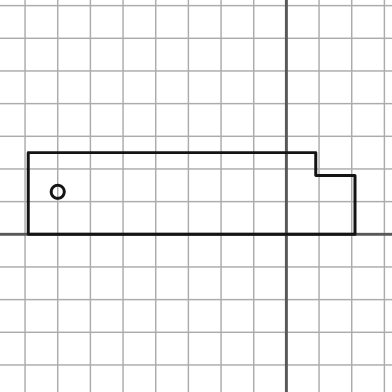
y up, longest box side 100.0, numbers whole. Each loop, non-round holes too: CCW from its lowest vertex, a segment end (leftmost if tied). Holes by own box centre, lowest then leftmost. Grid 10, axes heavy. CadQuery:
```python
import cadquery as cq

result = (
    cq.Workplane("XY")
    .moveTo(-79.0, 0.0)
    .lineTo(21.0, 0.0)
    .lineTo(21.0, 18.0)
    .lineTo(9.0, 18.0)
    .lineTo(9.0, 25.0)
    .lineTo(-79.0, 25.0)
    .close()
    .moveTo(-70.0, 13.0)
    .circle(2.0)
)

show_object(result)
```